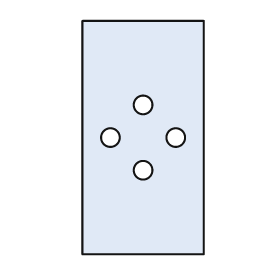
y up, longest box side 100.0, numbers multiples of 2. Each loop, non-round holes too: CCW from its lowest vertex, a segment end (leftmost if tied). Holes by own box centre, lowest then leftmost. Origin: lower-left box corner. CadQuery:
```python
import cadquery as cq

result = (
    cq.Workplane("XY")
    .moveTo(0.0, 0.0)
    .lineTo(52.0, 0.0)
    .lineTo(52.0, 100.0)
    .lineTo(0.0, 100.0)
    .close()
    .moveTo(26.0, 36.0)
    .circle(4.0)
    .moveTo(12.0, 50.0)
    .circle(4.0)
    .moveTo(40.0, 50.0)
    .circle(4.0)
    .moveTo(26.0, 64.0)
    .circle(4.0)
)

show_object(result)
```